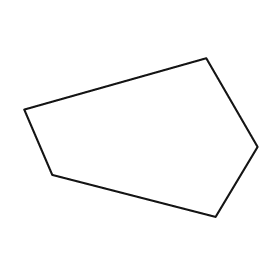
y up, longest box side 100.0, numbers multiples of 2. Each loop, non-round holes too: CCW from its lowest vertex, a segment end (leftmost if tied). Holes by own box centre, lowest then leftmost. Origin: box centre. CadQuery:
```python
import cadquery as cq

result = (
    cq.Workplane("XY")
    .moveTo(32.0, -34.0)
    .lineTo(50.0, -4.0)
    .lineTo(28.0, 34.0)
    .lineTo(-50.0, 12.0)
    .lineTo(-38.0, -16.0)
    .close()
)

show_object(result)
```